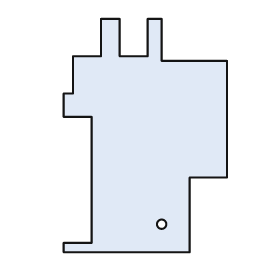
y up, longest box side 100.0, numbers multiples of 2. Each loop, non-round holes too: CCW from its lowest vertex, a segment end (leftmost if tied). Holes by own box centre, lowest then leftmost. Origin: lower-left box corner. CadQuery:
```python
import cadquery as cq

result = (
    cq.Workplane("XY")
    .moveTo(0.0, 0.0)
    .lineTo(54.0, 0.0)
    .lineTo(54.0, 32.0)
    .lineTo(70.0, 32.0)
    .lineTo(70.0, 82.0)
    .lineTo(42.0, 82.0)
    .lineTo(42.0, 100.0)
    .lineTo(36.0, 100.0)
    .lineTo(36.0, 84.0)
    .lineTo(24.0, 84.0)
    .lineTo(24.0, 100.0)
    .lineTo(16.0, 100.0)
    .lineTo(16.0, 84.0)
    .lineTo(4.0, 84.0)
    .lineTo(4.0, 68.0)
    .lineTo(0.0, 68.0)
    .lineTo(0.0, 58.0)
    .lineTo(12.0, 58.0)
    .lineTo(12.0, 4.0)
    .lineTo(0.0, 4.0)
    .close()
    .moveTo(42.0, 12.0)
    .circle(2.0)
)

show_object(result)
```